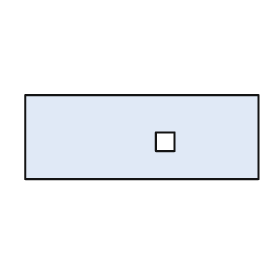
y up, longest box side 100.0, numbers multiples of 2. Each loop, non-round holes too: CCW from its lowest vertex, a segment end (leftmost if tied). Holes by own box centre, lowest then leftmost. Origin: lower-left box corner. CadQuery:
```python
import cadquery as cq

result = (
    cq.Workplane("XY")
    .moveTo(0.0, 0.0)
    .lineTo(100.0, 0.0)
    .lineTo(100.0, 36.0)
    .lineTo(0.0, 36.0)
    .close()
    .moveTo(56.0, 12.0)
    .lineTo(64.0, 12.0)
    .lineTo(64.0, 20.0)
    .lineTo(56.0, 20.0)
    .close()
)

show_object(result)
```